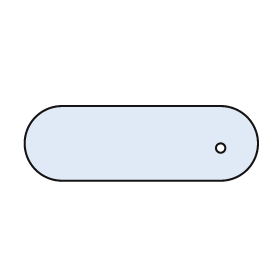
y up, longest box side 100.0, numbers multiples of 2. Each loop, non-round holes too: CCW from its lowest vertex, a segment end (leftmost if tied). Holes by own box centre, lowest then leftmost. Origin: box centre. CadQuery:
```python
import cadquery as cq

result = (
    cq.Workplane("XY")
    .moveTo(-34.0, -16.0)
    .lineTo(34.0, -16.0)
    .threePointArc((50.0, 0.0), (34.0, 16.0))
    .lineTo(-34.0, 16.0)
    .threePointArc((-50.0, 0.0), (-34.0, -16.0))
    .close()
    .moveTo(34.0, -2.0)
    .circle(2.0)
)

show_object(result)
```